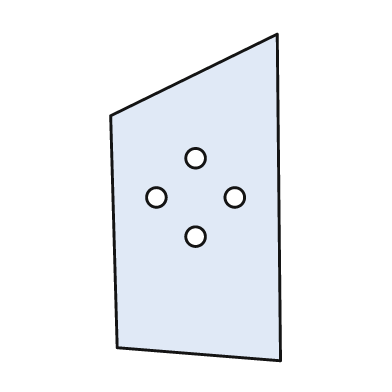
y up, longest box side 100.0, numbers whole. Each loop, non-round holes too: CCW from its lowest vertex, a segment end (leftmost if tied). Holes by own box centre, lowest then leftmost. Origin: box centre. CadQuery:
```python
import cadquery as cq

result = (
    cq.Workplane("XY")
    .moveTo(26.0, -50.0)
    .lineTo(25.0, 50.0)
    .lineTo(-26.0, 25.0)
    .lineTo(-24.0, -46.0)
    .close()
    .moveTo(0.0, -12.0)
    .circle(3.0)
    .moveTo(-12.0, 0.0)
    .circle(3.0)
    .moveTo(12.0, 0.0)
    .circle(3.0)
    .moveTo(0.0, 12.0)
    .circle(3.0)
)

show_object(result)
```